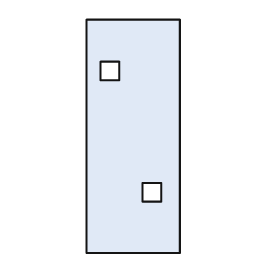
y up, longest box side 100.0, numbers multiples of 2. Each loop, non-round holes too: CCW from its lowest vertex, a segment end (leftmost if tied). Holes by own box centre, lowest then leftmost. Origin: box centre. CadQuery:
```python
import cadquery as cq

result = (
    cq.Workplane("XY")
    .moveTo(-20.0, -50.0)
    .lineTo(20.0, -50.0)
    .lineTo(20.0, 50.0)
    .lineTo(-20.0, 50.0)
    .close()
    .moveTo(4.0, -28.0)
    .lineTo(12.0, -28.0)
    .lineTo(12.0, -20.0)
    .lineTo(4.0, -20.0)
    .close()
    .moveTo(-14.0, 24.0)
    .lineTo(-6.0, 24.0)
    .lineTo(-6.0, 32.0)
    .lineTo(-14.0, 32.0)
    .close()
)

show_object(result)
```